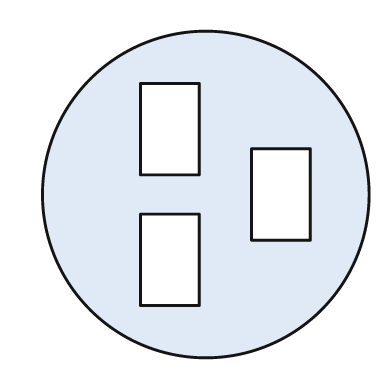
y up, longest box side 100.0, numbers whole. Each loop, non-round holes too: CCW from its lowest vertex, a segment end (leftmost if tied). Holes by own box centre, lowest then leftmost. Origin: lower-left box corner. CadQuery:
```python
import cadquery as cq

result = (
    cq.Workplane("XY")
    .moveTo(50.0, 50.0)
    .circle(50.0)
    .moveTo(30.0, 16.0)
    .lineTo(48.0, 16.0)
    .lineTo(48.0, 44.0)
    .lineTo(30.0, 44.0)
    .close()
    .moveTo(64.0, 36.0)
    .lineTo(82.0, 36.0)
    .lineTo(82.0, 64.0)
    .lineTo(64.0, 64.0)
    .close()
    .moveTo(30.0, 56.0)
    .lineTo(48.0, 56.0)
    .lineTo(48.0, 84.0)
    .lineTo(30.0, 84.0)
    .close()
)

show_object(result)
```